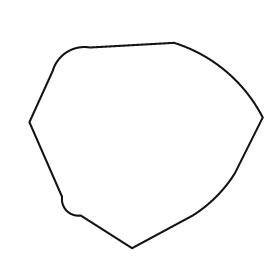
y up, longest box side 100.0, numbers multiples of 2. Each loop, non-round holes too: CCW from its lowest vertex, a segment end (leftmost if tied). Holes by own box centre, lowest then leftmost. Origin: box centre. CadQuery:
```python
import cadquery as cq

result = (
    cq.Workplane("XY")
    .moveTo(-6.0, -44.0)
    .lineTo(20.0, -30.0)
    .threePointArc((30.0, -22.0), (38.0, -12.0))
    .lineTo(50.0, 12.0)
    .threePointArc((34.0, 32.0), (12.0, 44.0))
    .lineTo(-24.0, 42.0)
    .threePointArc((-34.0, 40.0), (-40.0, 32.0))
    .lineTo(-50.0, 10.0)
    .lineTo(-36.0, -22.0)
    .threePointArc((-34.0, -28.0), (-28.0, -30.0))
    .close()
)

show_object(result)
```